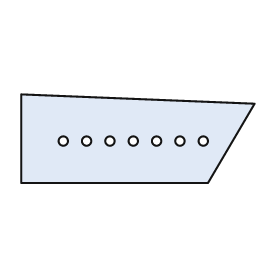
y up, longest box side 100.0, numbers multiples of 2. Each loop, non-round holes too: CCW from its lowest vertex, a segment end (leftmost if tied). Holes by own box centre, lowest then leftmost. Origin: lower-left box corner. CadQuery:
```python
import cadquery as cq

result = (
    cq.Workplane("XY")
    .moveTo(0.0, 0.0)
    .lineTo(80.0, 0.0)
    .lineTo(100.0, 34.0)
    .lineTo(0.0, 38.0)
    .close()
    .moveTo(18.0, 18.0)
    .circle(2.0)
    .moveTo(28.0, 18.0)
    .circle(2.0)
    .moveTo(38.0, 18.0)
    .circle(2.0)
    .moveTo(48.0, 18.0)
    .circle(2.0)
    .moveTo(58.0, 18.0)
    .circle(2.0)
    .moveTo(68.0, 18.0)
    .circle(2.0)
    .moveTo(78.0, 18.0)
    .circle(2.0)
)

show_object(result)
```